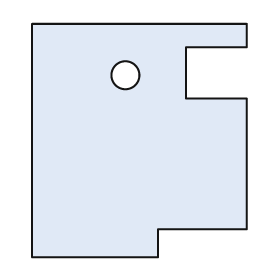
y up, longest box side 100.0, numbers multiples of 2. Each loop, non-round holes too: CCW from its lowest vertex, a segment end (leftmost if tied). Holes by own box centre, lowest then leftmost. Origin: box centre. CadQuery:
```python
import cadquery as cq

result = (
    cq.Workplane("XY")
    .moveTo(-46.0, -50.0)
    .lineTo(8.0, -50.0)
    .lineTo(8.0, -38.0)
    .lineTo(46.0, -38.0)
    .lineTo(46.0, 18.0)
    .lineTo(20.0, 18.0)
    .lineTo(20.0, 40.0)
    .lineTo(46.0, 40.0)
    .lineTo(46.0, 50.0)
    .lineTo(-46.0, 50.0)
    .close()
    .moveTo(-6.0, 28.0)
    .circle(6.0)
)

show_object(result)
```